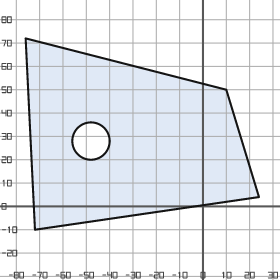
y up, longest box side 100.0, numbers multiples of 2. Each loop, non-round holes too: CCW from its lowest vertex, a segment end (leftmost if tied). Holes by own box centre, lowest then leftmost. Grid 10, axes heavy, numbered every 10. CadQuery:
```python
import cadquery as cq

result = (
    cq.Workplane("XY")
    .moveTo(-72.0, -10.0)
    .lineTo(24.0, 4.0)
    .lineTo(10.0, 50.0)
    .lineTo(-76.0, 72.0)
    .close()
    .moveTo(-48.0, 28.0)
    .circle(8.0)
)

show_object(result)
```